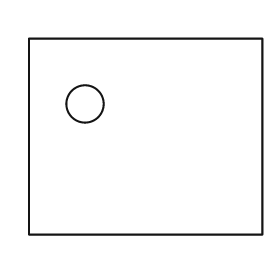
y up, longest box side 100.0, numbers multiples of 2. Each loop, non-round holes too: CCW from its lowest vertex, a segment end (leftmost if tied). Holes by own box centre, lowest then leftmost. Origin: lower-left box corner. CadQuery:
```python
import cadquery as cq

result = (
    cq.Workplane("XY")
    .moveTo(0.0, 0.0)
    .lineTo(100.0, 0.0)
    .lineTo(100.0, 84.0)
    .lineTo(0.0, 84.0)
    .close()
    .moveTo(24.0, 56.0)
    .circle(8.0)
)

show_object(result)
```